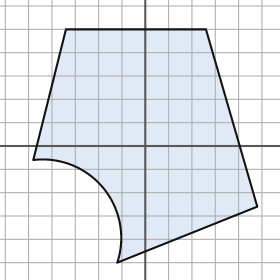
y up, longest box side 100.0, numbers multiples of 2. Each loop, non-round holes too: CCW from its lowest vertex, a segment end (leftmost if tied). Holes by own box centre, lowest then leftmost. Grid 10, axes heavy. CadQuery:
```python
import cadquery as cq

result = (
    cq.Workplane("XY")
    .moveTo(-12.0, -50.0)
    .lineTo(48.0, -26.0)
    .lineTo(26.0, 50.0)
    .lineTo(-34.0, 50.0)
    .lineTo(-48.0, -6.0)
    .threePointArc((-18.0, -18.0), (-12.0, -50.0))
    .close()
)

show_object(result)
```